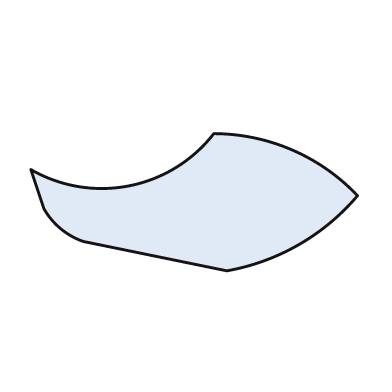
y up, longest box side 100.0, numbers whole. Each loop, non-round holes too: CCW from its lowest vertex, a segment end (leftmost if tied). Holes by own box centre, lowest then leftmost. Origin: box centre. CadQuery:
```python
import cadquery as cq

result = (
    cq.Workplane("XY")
    .moveTo(10.0, -21.0)
    .threePointArc((32.0, -13.0), (50.0, 2.0))
    .threePointArc((30.0, 16.0), (6.0, 21.0))
    .threePointArc((-20.0, 5.0), (-50.0, 10.0))
    .lineTo(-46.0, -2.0)
    .threePointArc((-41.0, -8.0), (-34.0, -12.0))
    .close()
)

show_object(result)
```